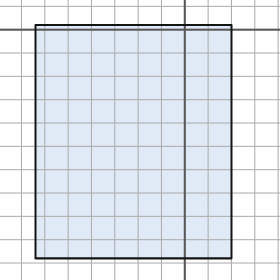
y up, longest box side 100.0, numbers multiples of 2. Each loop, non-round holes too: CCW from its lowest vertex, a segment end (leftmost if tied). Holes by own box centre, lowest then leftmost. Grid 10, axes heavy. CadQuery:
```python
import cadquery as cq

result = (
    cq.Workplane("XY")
    .moveTo(-64.0, -98.0)
    .lineTo(20.0, -98.0)
    .lineTo(20.0, 2.0)
    .lineTo(-64.0, 2.0)
    .close()
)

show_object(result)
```